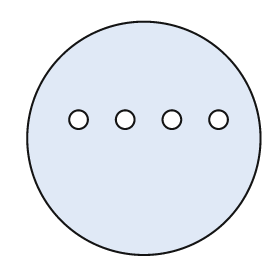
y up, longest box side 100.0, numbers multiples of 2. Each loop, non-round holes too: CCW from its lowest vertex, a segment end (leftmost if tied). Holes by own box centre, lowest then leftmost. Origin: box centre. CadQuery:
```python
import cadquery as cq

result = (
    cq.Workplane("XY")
    .moveTo(0.0, 0.0)
    .circle(50.0)
    .moveTo(-28.0, 8.0)
    .circle(4.0)
    .moveTo(-8.0, 8.0)
    .circle(4.0)
    .moveTo(12.0, 8.0)
    .circle(4.0)
    .moveTo(32.0, 8.0)
    .circle(4.0)
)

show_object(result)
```